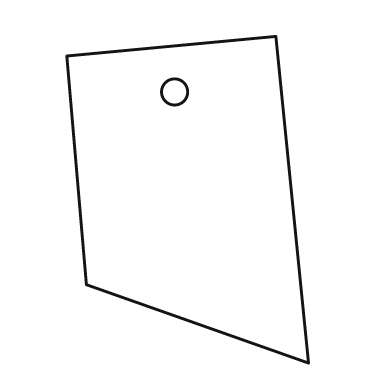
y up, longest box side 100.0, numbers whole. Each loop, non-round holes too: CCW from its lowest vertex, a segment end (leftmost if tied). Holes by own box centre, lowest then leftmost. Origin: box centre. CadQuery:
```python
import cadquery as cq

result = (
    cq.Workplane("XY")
    .moveTo(37.0, -50.0)
    .lineTo(27.0, 50.0)
    .lineTo(-37.0, 44.0)
    .lineTo(-31.0, -26.0)
    .close()
    .moveTo(-4.0, 33.0)
    .circle(4.0)
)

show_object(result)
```